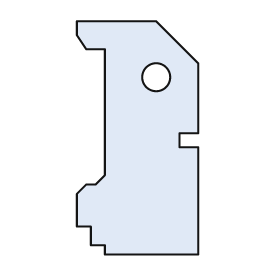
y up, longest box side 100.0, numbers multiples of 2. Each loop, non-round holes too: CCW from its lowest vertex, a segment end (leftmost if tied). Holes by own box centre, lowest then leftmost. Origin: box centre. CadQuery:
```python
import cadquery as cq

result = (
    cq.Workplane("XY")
    .moveTo(-14.0, -50.0)
    .lineTo(26.0, -50.0)
    .lineTo(26.0, -4.0)
    .lineTo(18.0, -4.0)
    .lineTo(18.0, 2.0)
    .lineTo(26.0, 2.0)
    .lineTo(26.0, 32.0)
    .lineTo(8.0, 50.0)
    .lineTo(-26.0, 50.0)
    .lineTo(-26.0, 44.0)
    .lineTo(-22.0, 38.0)
    .lineTo(-14.0, 38.0)
    .lineTo(-14.0, -16.0)
    .lineTo(-18.0, -20.0)
    .lineTo(-22.0, -20.0)
    .lineTo(-26.0, -24.0)
    .lineTo(-26.0, -38.0)
    .lineTo(-20.0, -38.0)
    .lineTo(-20.0, -46.0)
    .lineTo(-14.0, -46.0)
    .close()
    .moveTo(8.0, 26.0)
    .circle(6.0)
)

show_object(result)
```